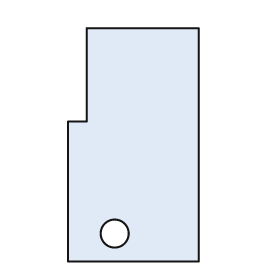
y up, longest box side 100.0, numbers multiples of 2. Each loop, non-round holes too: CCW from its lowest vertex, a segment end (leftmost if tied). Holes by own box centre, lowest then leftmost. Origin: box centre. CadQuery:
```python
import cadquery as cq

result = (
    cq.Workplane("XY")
    .moveTo(-28.0, -50.0)
    .lineTo(28.0, -50.0)
    .lineTo(28.0, 50.0)
    .lineTo(-20.0, 50.0)
    .lineTo(-20.0, 10.0)
    .lineTo(-28.0, 10.0)
    .close()
    .moveTo(-8.0, -38.0)
    .circle(6.0)
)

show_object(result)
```